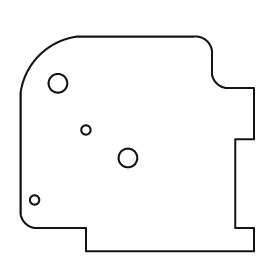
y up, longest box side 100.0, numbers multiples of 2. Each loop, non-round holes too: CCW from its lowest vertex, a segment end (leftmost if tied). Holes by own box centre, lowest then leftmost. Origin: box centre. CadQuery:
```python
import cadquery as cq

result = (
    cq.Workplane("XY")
    .moveTo(-22.0, -46.0)
    .lineTo(50.0, -46.0)
    .lineTo(50.0, -36.0)
    .lineTo(42.0, -36.0)
    .lineTo(42.0, 2.0)
    .lineTo(50.0, 2.0)
    .lineTo(50.0, 24.0)
    .lineTo(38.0, 24.0)
    .threePointArc((34.0, 26.0), (32.0, 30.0))
    .lineTo(32.0, 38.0)
    .threePointArc((30.0, 44.0), (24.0, 46.0))
    .lineTo(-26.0, 46.0)
    .threePointArc((-42.0, 38.0), (-50.0, 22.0))
    .lineTo(-50.0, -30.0)
    .threePointArc((-48.0, -34.0), (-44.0, -36.0))
    .lineTo(-22.0, -36.0)
    .close()
    .moveTo(-44.0, -24.0)
    .circle(2.0)
    .moveTo(-4.0, -6.0)
    .circle(4.0)
    .moveTo(-22.0, 6.0)
    .circle(2.0)
    .moveTo(-34.0, 26.0)
    .circle(4.0)
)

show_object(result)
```